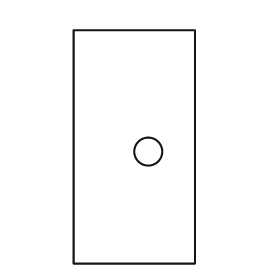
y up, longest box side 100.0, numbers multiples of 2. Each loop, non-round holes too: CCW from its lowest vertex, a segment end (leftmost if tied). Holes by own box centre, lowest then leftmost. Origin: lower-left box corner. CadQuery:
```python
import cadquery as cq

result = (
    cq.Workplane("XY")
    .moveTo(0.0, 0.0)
    .lineTo(52.0, 0.0)
    .lineTo(52.0, 100.0)
    .lineTo(0.0, 100.0)
    .close()
    .moveTo(32.0, 48.0)
    .circle(6.0)
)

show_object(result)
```